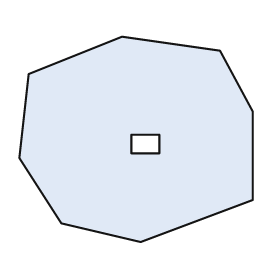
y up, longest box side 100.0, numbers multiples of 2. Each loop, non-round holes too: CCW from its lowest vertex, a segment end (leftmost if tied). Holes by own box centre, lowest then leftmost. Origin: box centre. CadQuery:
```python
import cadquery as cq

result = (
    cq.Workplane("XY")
    .moveTo(2.0, -44.0)
    .lineTo(50.0, -26.0)
    .lineTo(50.0, 12.0)
    .lineTo(36.0, 38.0)
    .lineTo(-6.0, 44.0)
    .lineTo(-46.0, 28.0)
    .lineTo(-50.0, -8.0)
    .lineTo(-32.0, -36.0)
    .close()
    .moveTo(-2.0, -6.0)
    .lineTo(10.0, -6.0)
    .lineTo(10.0, 2.0)
    .lineTo(-2.0, 2.0)
    .close()
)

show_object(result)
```